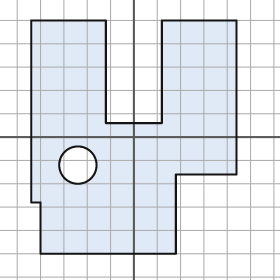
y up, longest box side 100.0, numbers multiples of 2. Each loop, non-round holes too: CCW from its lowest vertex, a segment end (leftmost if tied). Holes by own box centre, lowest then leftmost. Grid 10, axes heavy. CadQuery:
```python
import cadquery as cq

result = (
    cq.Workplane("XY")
    .moveTo(-40.0, -50.0)
    .lineTo(18.0, -50.0)
    .lineTo(18.0, -16.0)
    .lineTo(44.0, -16.0)
    .lineTo(44.0, 50.0)
    .lineTo(12.0, 50.0)
    .lineTo(12.0, 6.0)
    .lineTo(-12.0, 6.0)
    .lineTo(-12.0, 50.0)
    .lineTo(-44.0, 50.0)
    .lineTo(-44.0, -28.0)
    .lineTo(-40.0, -28.0)
    .close()
    .moveTo(-24.0, -12.0)
    .circle(8.0)
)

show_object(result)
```